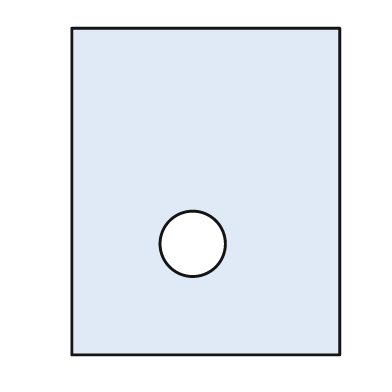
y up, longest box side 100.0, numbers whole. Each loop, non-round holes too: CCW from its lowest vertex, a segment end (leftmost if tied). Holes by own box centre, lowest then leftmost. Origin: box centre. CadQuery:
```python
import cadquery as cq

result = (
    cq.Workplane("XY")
    .moveTo(-41.0, -50.0)
    .lineTo(41.0, -50.0)
    .lineTo(41.0, 50.0)
    .lineTo(-41.0, 50.0)
    .close()
    .moveTo(-4.0, -16.0)
    .circle(10.0)
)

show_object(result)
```